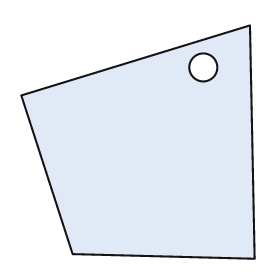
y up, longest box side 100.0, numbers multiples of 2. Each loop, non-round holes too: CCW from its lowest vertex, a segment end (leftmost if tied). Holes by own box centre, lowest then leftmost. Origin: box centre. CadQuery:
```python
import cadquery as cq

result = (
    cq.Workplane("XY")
    .moveTo(50.0, -50.0)
    .lineTo(48.0, 50.0)
    .lineTo(-50.0, 20.0)
    .lineTo(-28.0, -48.0)
    .close()
    .moveTo(28.0, 32.0)
    .circle(6.0)
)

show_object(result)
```